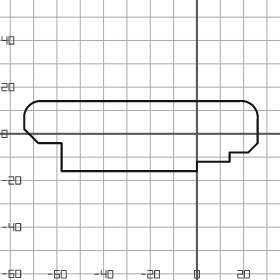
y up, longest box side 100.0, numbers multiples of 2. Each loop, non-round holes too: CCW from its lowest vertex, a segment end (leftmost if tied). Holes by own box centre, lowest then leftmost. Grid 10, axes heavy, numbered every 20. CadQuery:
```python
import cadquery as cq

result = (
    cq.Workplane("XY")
    .moveTo(-58.0, -16.0)
    .lineTo(0.0, -16.0)
    .lineTo(0.0, -12.0)
    .lineTo(14.0, -12.0)
    .lineTo(14.0, -8.0)
    .lineTo(22.0, -8.0)
    .lineTo(26.0, -4.0)
    .lineTo(26.0, 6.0)
    .threePointArc((24.0, 12.0), (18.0, 14.0))
    .lineTo(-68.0, 14.0)
    .threePointArc((-72.0, 12.0), (-74.0, 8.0))
    .lineTo(-74.0, 2.0)
    .lineTo(-68.0, -4.0)
    .lineTo(-58.0, -4.0)
    .close()
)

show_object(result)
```